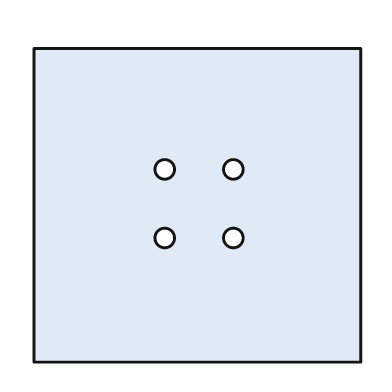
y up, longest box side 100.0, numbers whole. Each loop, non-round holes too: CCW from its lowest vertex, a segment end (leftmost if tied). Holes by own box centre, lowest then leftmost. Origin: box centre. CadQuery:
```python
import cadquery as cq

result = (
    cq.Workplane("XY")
    .moveTo(-50.0, -48.0)
    .lineTo(50.0, -48.0)
    .lineTo(50.0, 48.0)
    .lineTo(-50.0, 48.0)
    .close()
    .moveTo(-10.0, -10.0)
    .circle(3.0)
    .moveTo(11.0, -10.0)
    .circle(3.0)
    .moveTo(-10.0, 11.0)
    .circle(3.0)
    .moveTo(11.0, 11.0)
    .circle(3.0)
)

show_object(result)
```